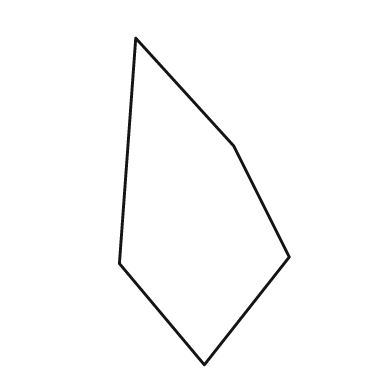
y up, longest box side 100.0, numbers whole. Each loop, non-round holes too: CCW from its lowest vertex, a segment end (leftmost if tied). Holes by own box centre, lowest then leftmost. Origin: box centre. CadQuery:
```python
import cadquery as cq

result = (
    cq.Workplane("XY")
    .moveTo(0.0, -50.0)
    .lineTo(26.0, -17.0)
    .lineTo(9.0, 17.0)
    .lineTo(-21.0, 50.0)
    .lineTo(-26.0, -19.0)
    .close()
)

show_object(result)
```